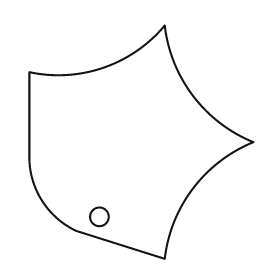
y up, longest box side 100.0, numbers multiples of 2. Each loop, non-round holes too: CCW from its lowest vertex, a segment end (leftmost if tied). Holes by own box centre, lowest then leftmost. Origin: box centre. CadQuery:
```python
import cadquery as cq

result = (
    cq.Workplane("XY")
    .moveTo(10.0, -50.0)
    .threePointArc((22.0, -20.0), (48.0, 0.0))
    .threePointArc((22.0, 20.0), (10.0, 50.0))
    .threePointArc((-16.0, 32.0), (-48.0, 30.0))
    .lineTo(-48.0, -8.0)
    .threePointArc((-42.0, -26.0), (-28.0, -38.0))
    .close()
    .moveTo(-18.0, -32.0)
    .circle(4.0)
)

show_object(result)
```